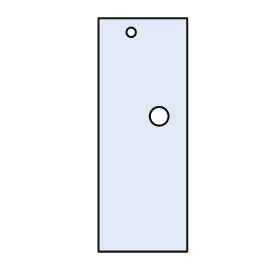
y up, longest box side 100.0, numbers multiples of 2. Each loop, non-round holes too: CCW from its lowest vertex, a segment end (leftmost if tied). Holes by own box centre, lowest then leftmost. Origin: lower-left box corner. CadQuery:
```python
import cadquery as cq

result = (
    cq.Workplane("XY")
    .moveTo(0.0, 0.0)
    .lineTo(38.0, 0.0)
    .lineTo(38.0, 100.0)
    .lineTo(0.0, 100.0)
    .close()
    .moveTo(26.0, 58.0)
    .circle(4.0)
    .moveTo(14.0, 94.0)
    .circle(2.0)
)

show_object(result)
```